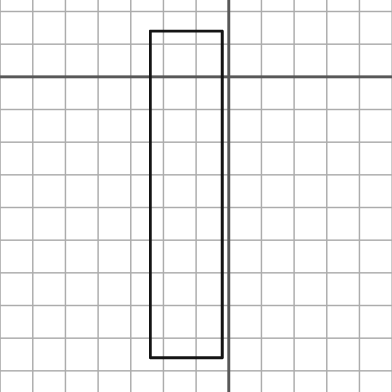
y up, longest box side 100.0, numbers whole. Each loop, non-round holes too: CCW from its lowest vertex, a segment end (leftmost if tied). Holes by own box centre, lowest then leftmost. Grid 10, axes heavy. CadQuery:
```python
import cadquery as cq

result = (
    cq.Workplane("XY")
    .moveTo(-24.0, -86.0)
    .lineTo(-2.0, -86.0)
    .lineTo(-2.0, 14.0)
    .lineTo(-24.0, 14.0)
    .close()
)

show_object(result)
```